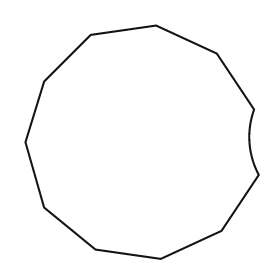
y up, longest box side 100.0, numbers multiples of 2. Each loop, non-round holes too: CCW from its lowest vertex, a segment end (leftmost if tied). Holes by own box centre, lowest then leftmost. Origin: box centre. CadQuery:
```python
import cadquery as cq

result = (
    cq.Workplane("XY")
    .moveTo(8.0, -50.0)
    .lineTo(34.0, -38.0)
    .lineTo(50.0, -14.0)
    .threePointArc((46.0, 0.0), (48.0, 14.0))
    .lineTo(32.0, 38.0)
    .lineTo(6.0, 50.0)
    .lineTo(-22.0, 46.0)
    .lineTo(-42.0, 26.0)
    .lineTo(-50.0, 0.0)
    .lineTo(-42.0, -28.0)
    .lineTo(-20.0, -46.0)
    .close()
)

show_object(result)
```